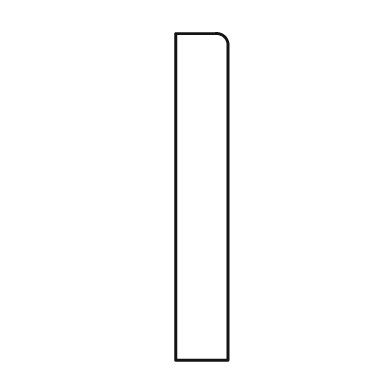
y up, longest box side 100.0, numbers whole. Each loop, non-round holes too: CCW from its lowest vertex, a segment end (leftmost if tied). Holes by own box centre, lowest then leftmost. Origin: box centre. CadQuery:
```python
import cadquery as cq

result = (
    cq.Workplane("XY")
    .moveTo(-8.0, -50.0)
    .lineTo(8.0, -50.0)
    .lineTo(8.0, 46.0)
    .threePointArc((7.0, 49.0), (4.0, 50.0))
    .lineTo(-8.0, 50.0)
    .close()
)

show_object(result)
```